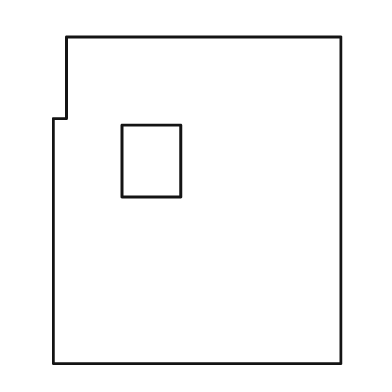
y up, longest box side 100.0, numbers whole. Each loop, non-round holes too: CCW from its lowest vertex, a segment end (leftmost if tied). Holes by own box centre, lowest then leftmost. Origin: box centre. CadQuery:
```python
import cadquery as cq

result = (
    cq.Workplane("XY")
    .moveTo(-44.0, -50.0)
    .lineTo(44.0, -50.0)
    .lineTo(44.0, 50.0)
    .lineTo(-40.0, 50.0)
    .lineTo(-40.0, 25.0)
    .lineTo(-44.0, 25.0)
    .close()
    .moveTo(-23.0, 1.0)
    .lineTo(-5.0, 1.0)
    .lineTo(-5.0, 23.0)
    .lineTo(-23.0, 23.0)
    .close()
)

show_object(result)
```